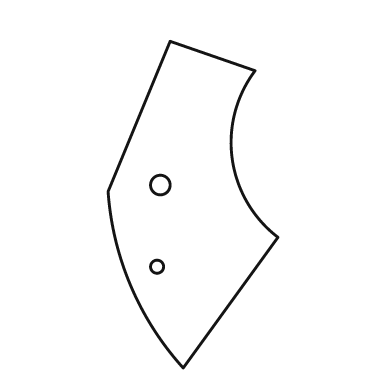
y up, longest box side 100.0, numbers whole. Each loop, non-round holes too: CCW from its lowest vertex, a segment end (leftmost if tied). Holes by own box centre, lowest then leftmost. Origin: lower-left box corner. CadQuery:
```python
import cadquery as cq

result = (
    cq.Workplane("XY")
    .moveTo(23.0, 0.0)
    .lineTo(52.0, 40.0)
    .threePointArc((38.0, 64.0), (45.0, 91.0))
    .lineTo(19.0, 100.0)
    .lineTo(0.0, 54.0)
    .threePointArc((7.0, 25.0), (23.0, 0.0))
    .close()
    .moveTo(15.0, 31.0)
    .circle(2.0)
    .moveTo(16.0, 56.0)
    .circle(3.0)
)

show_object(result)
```